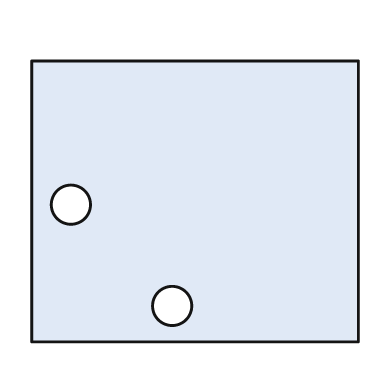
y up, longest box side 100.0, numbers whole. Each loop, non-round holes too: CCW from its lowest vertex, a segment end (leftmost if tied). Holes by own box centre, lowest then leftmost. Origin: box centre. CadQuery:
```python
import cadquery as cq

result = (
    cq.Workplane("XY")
    .moveTo(-50.0, -43.0)
    .lineTo(50.0, -43.0)
    .lineTo(50.0, 43.0)
    .lineTo(-50.0, 43.0)
    .close()
    .moveTo(-7.0, -32.0)
    .circle(6.0)
    .moveTo(-38.0, -1.0)
    .circle(6.0)
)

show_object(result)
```